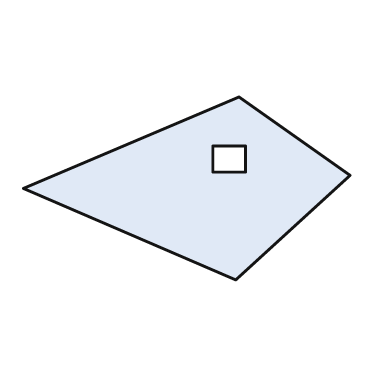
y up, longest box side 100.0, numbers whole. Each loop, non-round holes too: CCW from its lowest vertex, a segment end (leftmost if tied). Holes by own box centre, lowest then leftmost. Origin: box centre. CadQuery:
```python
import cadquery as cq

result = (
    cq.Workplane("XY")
    .moveTo(15.0, -28.0)
    .lineTo(50.0, 4.0)
    .lineTo(16.0, 28.0)
    .lineTo(-50.0, 0.0)
    .close()
    .moveTo(8.0, 5.0)
    .lineTo(18.0, 5.0)
    .lineTo(18.0, 13.0)
    .lineTo(8.0, 13.0)
    .close()
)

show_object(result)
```